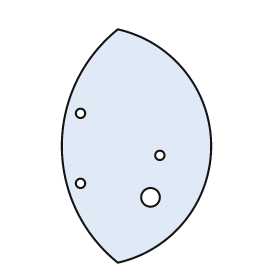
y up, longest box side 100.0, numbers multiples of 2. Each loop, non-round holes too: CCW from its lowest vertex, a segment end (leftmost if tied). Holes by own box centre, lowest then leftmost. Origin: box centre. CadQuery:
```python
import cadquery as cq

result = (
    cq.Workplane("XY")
    .moveTo(-8.0, -50.0)
    .threePointArc((32.0, 0.0), (-8.0, 50.0))
    .threePointArc((-32.0, 0.0), (-8.0, -50.0))
    .close()
    .moveTo(6.0, -22.0)
    .circle(4.0)
    .moveTo(-24.0, -16.0)
    .circle(2.0)
    .moveTo(10.0, -4.0)
    .circle(2.0)
    .moveTo(-24.0, 14.0)
    .circle(2.0)
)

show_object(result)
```